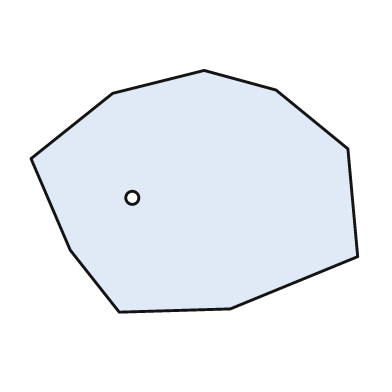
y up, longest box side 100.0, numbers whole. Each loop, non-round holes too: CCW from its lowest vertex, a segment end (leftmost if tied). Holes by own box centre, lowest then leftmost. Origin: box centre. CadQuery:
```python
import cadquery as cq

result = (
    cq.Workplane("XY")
    .moveTo(-23.0, -37.0)
    .lineTo(11.0, -36.0)
    .lineTo(50.0, -20.0)
    .lineTo(47.0, 13.0)
    .lineTo(25.0, 31.0)
    .lineTo(3.0, 37.0)
    .lineTo(-25.0, 30.0)
    .lineTo(-50.0, 10.0)
    .lineTo(-38.0, -18.0)
    .close()
    .moveTo(-19.0, -2.0)
    .circle(2.0)
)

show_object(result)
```